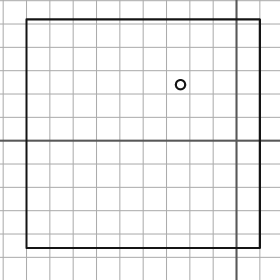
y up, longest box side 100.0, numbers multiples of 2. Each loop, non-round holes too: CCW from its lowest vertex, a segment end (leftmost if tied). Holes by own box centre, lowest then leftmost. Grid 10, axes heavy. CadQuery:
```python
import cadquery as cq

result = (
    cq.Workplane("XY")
    .moveTo(-90.0, -46.0)
    .lineTo(10.0, -46.0)
    .lineTo(10.0, 52.0)
    .lineTo(-90.0, 52.0)
    .close()
    .moveTo(-24.0, 24.0)
    .circle(2.0)
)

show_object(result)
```